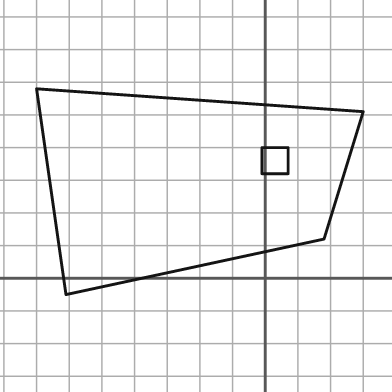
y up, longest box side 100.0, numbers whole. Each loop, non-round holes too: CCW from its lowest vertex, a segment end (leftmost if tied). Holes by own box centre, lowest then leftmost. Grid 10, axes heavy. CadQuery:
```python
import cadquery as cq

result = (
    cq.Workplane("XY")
    .moveTo(-61.0, -5.0)
    .lineTo(18.0, 12.0)
    .lineTo(30.0, 51.0)
    .lineTo(-70.0, 58.0)
    .close()
    .moveTo(-1.0, 32.0)
    .lineTo(7.0, 32.0)
    .lineTo(7.0, 40.0)
    .lineTo(-1.0, 40.0)
    .close()
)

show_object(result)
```